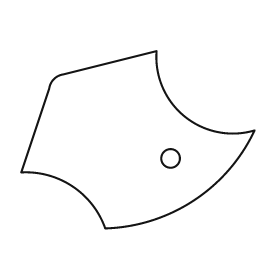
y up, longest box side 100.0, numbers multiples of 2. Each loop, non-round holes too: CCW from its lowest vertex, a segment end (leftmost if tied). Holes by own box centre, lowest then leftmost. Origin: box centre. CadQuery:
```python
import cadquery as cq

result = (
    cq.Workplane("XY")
    .moveTo(-14.0, -38.0)
    .threePointArc((24.0, -26.0), (50.0, 4.0))
    .threePointArc((20.0, 10.0), (8.0, 38.0))
    .lineTo(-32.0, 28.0)
    .threePointArc((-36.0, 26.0), (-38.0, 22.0))
    .lineTo(-50.0, -14.0)
    .threePointArc((-28.0, -20.0), (-14.0, -38.0))
    .close()
    .moveTo(14.0, -8.0)
    .circle(4.0)
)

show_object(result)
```